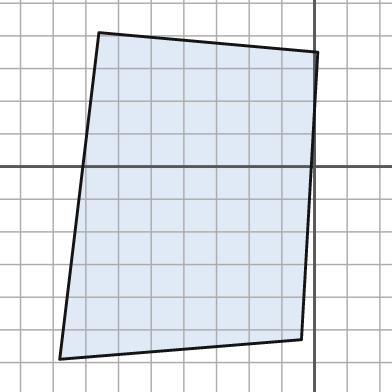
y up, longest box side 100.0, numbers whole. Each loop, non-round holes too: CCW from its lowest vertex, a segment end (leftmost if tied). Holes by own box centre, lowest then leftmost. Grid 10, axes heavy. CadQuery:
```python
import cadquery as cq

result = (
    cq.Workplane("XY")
    .moveTo(-78.0, -59.0)
    .lineTo(-4.0, -53.0)
    .lineTo(1.0, 35.0)
    .lineTo(-66.0, 41.0)
    .close()
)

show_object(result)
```